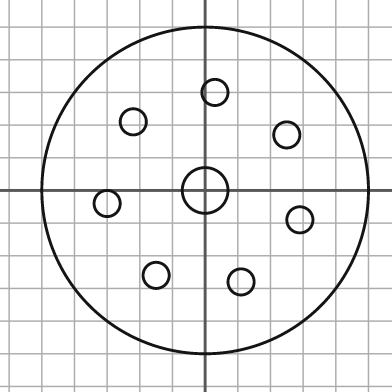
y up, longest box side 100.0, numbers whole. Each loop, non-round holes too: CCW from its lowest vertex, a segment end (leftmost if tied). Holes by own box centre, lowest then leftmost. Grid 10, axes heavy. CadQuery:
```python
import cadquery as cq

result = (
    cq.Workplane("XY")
    .moveTo(0.0, 0.0)
    .circle(50.0)
    .moveTo(11.0, -28.0)
    .circle(4.0)
    .moveTo(-15.0, -26.0)
    .circle(4.0)
    .moveTo(29.0, -9.0)
    .circle(4.0)
    .moveTo(-30.0, -4.0)
    .circle(4.0)
    .moveTo(0.0, 0.0)
    .circle(7.0)
    .moveTo(25.0, 17.0)
    .circle(4.0)
    .moveTo(-22.0, 21.0)
    .circle(4.0)
    .moveTo(3.0, 30.0)
    .circle(4.0)
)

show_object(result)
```